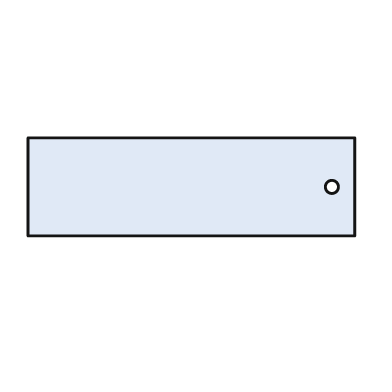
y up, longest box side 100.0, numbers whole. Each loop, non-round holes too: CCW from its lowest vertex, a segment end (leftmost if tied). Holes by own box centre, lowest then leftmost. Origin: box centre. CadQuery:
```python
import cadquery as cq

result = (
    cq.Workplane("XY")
    .moveTo(-50.0, -15.0)
    .lineTo(50.0, -15.0)
    .lineTo(50.0, 15.0)
    .lineTo(-50.0, 15.0)
    .close()
    .moveTo(43.0, 0.0)
    .circle(2.0)
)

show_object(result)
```